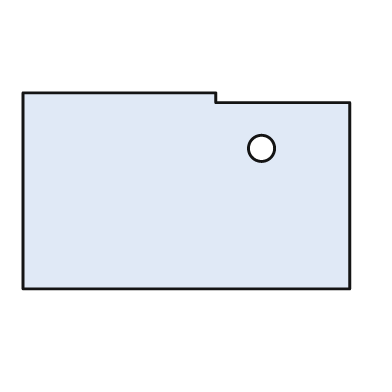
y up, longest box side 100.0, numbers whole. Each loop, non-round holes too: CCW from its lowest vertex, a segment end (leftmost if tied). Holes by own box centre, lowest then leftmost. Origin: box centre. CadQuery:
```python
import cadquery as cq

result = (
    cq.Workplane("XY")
    .moveTo(-50.0, -30.0)
    .lineTo(50.0, -30.0)
    .lineTo(50.0, 27.0)
    .lineTo(9.0, 27.0)
    .lineTo(9.0, 30.0)
    .lineTo(-50.0, 30.0)
    .close()
    .moveTo(23.0, 13.0)
    .circle(4.0)
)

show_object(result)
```